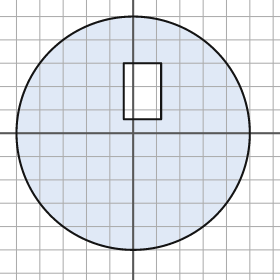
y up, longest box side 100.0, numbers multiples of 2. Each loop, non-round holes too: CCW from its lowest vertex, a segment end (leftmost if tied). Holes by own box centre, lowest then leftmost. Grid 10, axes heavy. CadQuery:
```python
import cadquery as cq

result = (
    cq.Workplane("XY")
    .moveTo(0.0, 0.0)
    .circle(50.0)
    .moveTo(-4.0, 6.0)
    .lineTo(12.0, 6.0)
    .lineTo(12.0, 30.0)
    .lineTo(-4.0, 30.0)
    .close()
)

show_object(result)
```